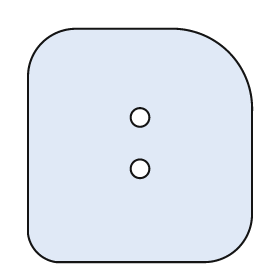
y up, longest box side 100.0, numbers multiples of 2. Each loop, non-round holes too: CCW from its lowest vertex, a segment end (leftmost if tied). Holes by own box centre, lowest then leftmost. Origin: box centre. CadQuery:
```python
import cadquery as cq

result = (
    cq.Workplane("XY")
    .moveTo(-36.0, -50.0)
    .lineTo(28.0, -50.0)
    .threePointArc((42.0, -44.0), (48.0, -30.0))
    .lineTo(48.0, 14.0)
    .threePointArc((38.0, 40.0), (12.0, 50.0))
    .lineTo(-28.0, 50.0)
    .threePointArc((-42.0, 44.0), (-48.0, 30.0))
    .lineTo(-48.0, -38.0)
    .threePointArc((-44.0, -46.0), (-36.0, -50.0))
    .close()
    .moveTo(0.0, -10.0)
    .circle(4.0)
    .moveTo(0.0, 12.0)
    .circle(4.0)
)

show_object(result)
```